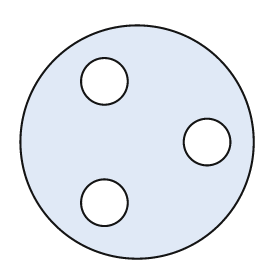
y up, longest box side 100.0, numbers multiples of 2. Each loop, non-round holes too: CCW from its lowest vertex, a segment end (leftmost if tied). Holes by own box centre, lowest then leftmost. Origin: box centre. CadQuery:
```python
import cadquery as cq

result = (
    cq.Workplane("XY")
    .moveTo(0.0, 0.0)
    .circle(50.0)
    .moveTo(-14.0, -26.0)
    .circle(10.0)
    .moveTo(30.0, 0.0)
    .circle(10.0)
    .moveTo(-14.0, 26.0)
    .circle(10.0)
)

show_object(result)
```